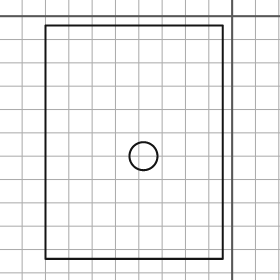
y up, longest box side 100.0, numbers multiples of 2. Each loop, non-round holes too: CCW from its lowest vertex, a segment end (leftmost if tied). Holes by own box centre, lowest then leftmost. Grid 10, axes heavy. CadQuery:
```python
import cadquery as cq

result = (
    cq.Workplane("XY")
    .moveTo(-80.0, -104.0)
    .lineTo(-4.0, -104.0)
    .lineTo(-4.0, -4.0)
    .lineTo(-80.0, -4.0)
    .close()
    .moveTo(-38.0, -60.0)
    .circle(6.0)
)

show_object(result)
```